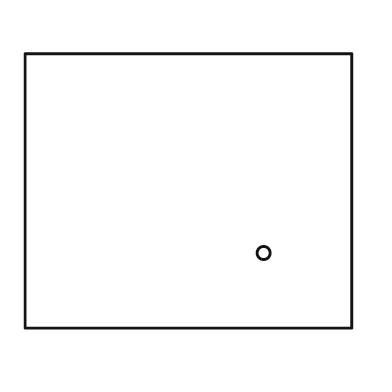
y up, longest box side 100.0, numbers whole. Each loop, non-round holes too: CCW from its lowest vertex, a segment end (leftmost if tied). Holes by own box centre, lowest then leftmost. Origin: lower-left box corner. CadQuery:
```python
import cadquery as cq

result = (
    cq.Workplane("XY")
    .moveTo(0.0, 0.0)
    .lineTo(100.0, 0.0)
    .lineTo(100.0, 84.0)
    .lineTo(0.0, 84.0)
    .close()
    .moveTo(73.0, 23.0)
    .circle(2.0)
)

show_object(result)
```